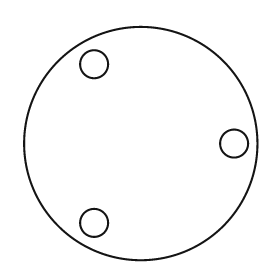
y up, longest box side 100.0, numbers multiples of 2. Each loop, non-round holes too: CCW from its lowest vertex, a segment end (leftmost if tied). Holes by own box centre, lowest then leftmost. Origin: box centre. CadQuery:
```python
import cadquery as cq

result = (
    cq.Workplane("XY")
    .moveTo(0.0, 0.0)
    .circle(50.0)
    .moveTo(-20.0, -34.0)
    .circle(6.0)
    .moveTo(40.0, 0.0)
    .circle(6.0)
    .moveTo(-20.0, 34.0)
    .circle(6.0)
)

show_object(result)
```